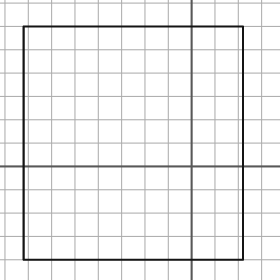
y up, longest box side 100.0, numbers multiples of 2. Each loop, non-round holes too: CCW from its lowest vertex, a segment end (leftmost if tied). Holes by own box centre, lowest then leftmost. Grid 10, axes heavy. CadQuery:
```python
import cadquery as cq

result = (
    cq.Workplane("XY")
    .moveTo(-72.0, -40.0)
    .lineTo(22.0, -40.0)
    .lineTo(22.0, 60.0)
    .lineTo(-72.0, 60.0)
    .close()
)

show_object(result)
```